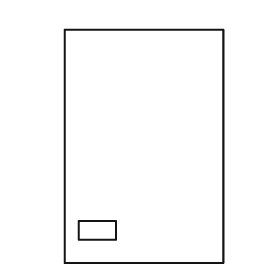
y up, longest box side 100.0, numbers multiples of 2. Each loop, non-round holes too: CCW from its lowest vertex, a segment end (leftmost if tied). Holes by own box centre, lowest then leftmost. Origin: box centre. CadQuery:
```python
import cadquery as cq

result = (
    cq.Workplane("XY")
    .moveTo(-34.0, -50.0)
    .lineTo(34.0, -50.0)
    .lineTo(34.0, 50.0)
    .lineTo(-34.0, 50.0)
    .close()
    .moveTo(-28.0, -40.0)
    .lineTo(-12.0, -40.0)
    .lineTo(-12.0, -32.0)
    .lineTo(-28.0, -32.0)
    .close()
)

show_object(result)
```